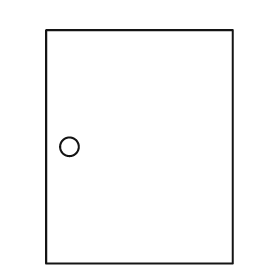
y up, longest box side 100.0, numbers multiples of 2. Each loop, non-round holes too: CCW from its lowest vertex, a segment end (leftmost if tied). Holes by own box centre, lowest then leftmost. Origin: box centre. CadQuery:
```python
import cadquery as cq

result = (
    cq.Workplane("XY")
    .moveTo(-40.0, -50.0)
    .lineTo(40.0, -50.0)
    .lineTo(40.0, 50.0)
    .lineTo(-40.0, 50.0)
    .close()
    .moveTo(-30.0, 0.0)
    .circle(4.0)
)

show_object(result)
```